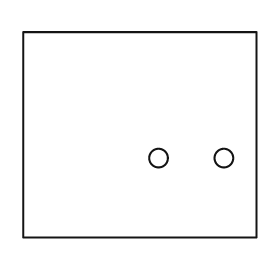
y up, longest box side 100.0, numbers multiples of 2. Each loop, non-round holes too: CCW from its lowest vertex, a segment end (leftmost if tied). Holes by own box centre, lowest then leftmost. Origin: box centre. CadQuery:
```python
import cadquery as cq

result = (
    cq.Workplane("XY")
    .moveTo(-50.0, -44.0)
    .lineTo(50.0, -44.0)
    .lineTo(50.0, 44.0)
    .lineTo(-50.0, 44.0)
    .close()
    .moveTo(8.0, -10.0)
    .circle(4.0)
    .moveTo(36.0, -10.0)
    .circle(4.0)
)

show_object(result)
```